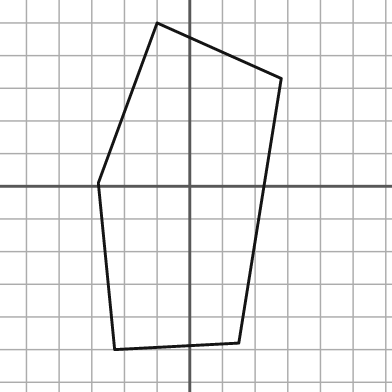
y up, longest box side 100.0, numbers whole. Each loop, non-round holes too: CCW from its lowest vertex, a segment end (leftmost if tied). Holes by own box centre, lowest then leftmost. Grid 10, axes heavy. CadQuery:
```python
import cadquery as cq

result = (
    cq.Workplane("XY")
    .moveTo(-23.0, -50.0)
    .lineTo(15.0, -48.0)
    .lineTo(28.0, 33.0)
    .lineTo(-10.0, 50.0)
    .lineTo(-28.0, 1.0)
    .close()
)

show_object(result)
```